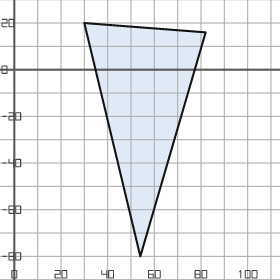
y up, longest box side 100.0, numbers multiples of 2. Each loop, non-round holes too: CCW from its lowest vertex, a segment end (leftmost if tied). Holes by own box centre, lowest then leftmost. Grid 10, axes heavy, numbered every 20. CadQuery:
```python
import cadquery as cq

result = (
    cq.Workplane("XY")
    .moveTo(54.0, -80.0)
    .lineTo(82.0, 16.0)
    .lineTo(30.0, 20.0)
    .close()
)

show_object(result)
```